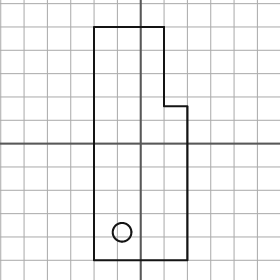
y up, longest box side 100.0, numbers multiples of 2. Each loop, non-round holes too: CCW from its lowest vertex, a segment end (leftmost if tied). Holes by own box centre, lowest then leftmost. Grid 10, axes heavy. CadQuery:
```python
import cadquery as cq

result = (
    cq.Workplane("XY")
    .moveTo(-20.0, -50.0)
    .lineTo(20.0, -50.0)
    .lineTo(20.0, 16.0)
    .lineTo(10.0, 16.0)
    .lineTo(10.0, 50.0)
    .lineTo(-20.0, 50.0)
    .close()
    .moveTo(-8.0, -38.0)
    .circle(4.0)
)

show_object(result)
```